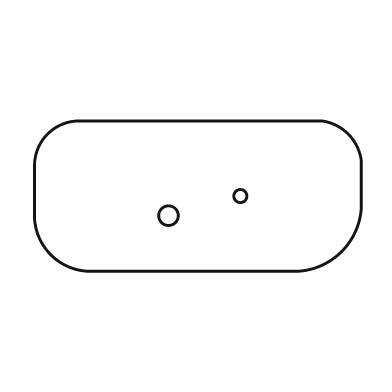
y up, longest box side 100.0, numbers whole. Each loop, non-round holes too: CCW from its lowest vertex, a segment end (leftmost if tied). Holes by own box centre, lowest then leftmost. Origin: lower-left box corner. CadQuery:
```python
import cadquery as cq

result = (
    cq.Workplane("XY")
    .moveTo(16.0, 0.0)
    .lineTo(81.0, 0.0)
    .threePointArc((94.0, 6.0), (100.0, 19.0))
    .lineTo(100.0, 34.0)
    .threePointArc((96.0, 42.0), (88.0, 46.0))
    .lineTo(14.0, 46.0)
    .threePointArc((4.0, 42.0), (0.0, 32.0))
    .lineTo(0.0, 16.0)
    .threePointArc((5.0, 5.0), (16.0, 0.0))
    .close()
    .moveTo(41.0, 17.0)
    .circle(3.0)
    .moveTo(63.0, 23.0)
    .circle(2.0)
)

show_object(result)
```